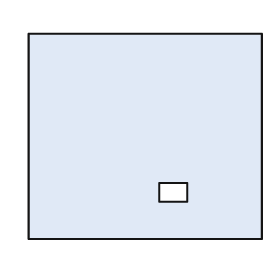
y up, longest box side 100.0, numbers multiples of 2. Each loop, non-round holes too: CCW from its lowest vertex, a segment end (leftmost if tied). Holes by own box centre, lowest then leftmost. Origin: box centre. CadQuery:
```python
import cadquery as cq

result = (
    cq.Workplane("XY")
    .moveTo(-50.0, -44.0)
    .lineTo(50.0, -44.0)
    .lineTo(50.0, 44.0)
    .lineTo(-50.0, 44.0)
    .close()
    .moveTo(6.0, -28.0)
    .lineTo(18.0, -28.0)
    .lineTo(18.0, -20.0)
    .lineTo(6.0, -20.0)
    .close()
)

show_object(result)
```